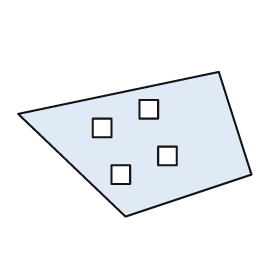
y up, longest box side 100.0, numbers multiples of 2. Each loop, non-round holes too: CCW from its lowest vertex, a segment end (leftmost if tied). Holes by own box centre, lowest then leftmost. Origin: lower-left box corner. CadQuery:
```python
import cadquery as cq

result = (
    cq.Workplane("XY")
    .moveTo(46.0, 0.0)
    .lineTo(100.0, 18.0)
    .lineTo(86.0, 62.0)
    .lineTo(0.0, 44.0)
    .close()
    .moveTo(40.0, 14.0)
    .lineTo(48.0, 14.0)
    .lineTo(48.0, 22.0)
    .lineTo(40.0, 22.0)
    .close()
    .moveTo(60.0, 22.0)
    .lineTo(68.0, 22.0)
    .lineTo(68.0, 30.0)
    .lineTo(60.0, 30.0)
    .close()
    .moveTo(32.0, 34.0)
    .lineTo(40.0, 34.0)
    .lineTo(40.0, 42.0)
    .lineTo(32.0, 42.0)
    .close()
    .moveTo(52.0, 42.0)
    .lineTo(60.0, 42.0)
    .lineTo(60.0, 50.0)
    .lineTo(52.0, 50.0)
    .close()
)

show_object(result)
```